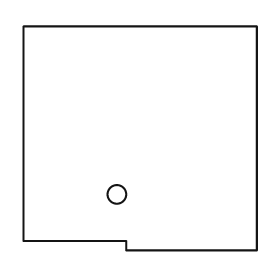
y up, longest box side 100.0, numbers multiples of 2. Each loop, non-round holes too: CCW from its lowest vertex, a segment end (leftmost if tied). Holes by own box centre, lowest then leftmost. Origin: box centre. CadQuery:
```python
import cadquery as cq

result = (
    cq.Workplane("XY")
    .moveTo(-6.0, -48.0)
    .lineTo(50.0, -48.0)
    .lineTo(50.0, 48.0)
    .lineTo(-50.0, 48.0)
    .lineTo(-50.0, -44.0)
    .lineTo(-6.0, -44.0)
    .close()
    .moveTo(-10.0, -24.0)
    .circle(4.0)
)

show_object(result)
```